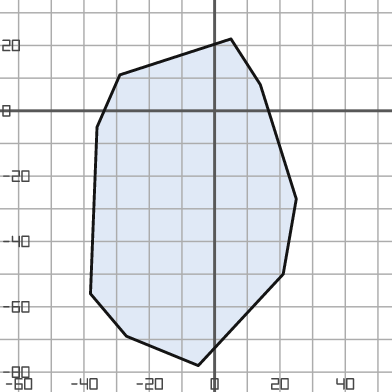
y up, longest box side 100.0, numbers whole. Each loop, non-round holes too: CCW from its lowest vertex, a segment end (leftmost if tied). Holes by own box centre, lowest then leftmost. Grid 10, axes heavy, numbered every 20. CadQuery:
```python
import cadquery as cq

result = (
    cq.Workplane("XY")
    .moveTo(-5.0, -78.0)
    .lineTo(21.0, -50.0)
    .lineTo(25.0, -27.0)
    .lineTo(14.0, 8.0)
    .lineTo(5.0, 22.0)
    .lineTo(-29.0, 11.0)
    .lineTo(-36.0, -5.0)
    .lineTo(-38.0, -56.0)
    .lineTo(-27.0, -69.0)
    .close()
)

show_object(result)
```